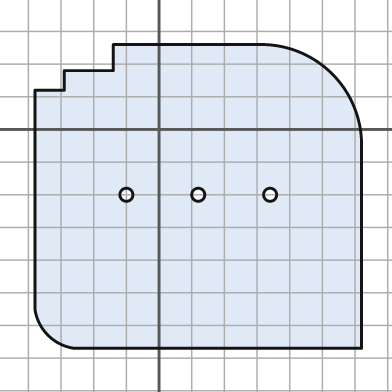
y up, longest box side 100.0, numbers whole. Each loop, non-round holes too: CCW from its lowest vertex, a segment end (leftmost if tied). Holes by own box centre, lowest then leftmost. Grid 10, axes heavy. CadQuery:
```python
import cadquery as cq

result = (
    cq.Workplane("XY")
    .moveTo(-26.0, -67.0)
    .lineTo(62.0, -67.0)
    .lineTo(62.0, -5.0)
    .threePointArc((53.0, 17.0), (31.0, 26.0))
    .lineTo(-14.0, 26.0)
    .lineTo(-14.0, 18.0)
    .lineTo(-29.0, 18.0)
    .lineTo(-29.0, 12.0)
    .lineTo(-38.0, 12.0)
    .lineTo(-38.0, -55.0)
    .threePointArc((-34.0, -63.0), (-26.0, -67.0))
    .close()
    .moveTo(-10.0, -20.0)
    .circle(2.0)
    .moveTo(12.0, -20.0)
    .circle(2.0)
    .moveTo(34.0, -20.0)
    .circle(2.0)
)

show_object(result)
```